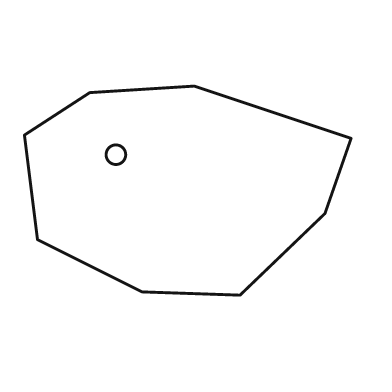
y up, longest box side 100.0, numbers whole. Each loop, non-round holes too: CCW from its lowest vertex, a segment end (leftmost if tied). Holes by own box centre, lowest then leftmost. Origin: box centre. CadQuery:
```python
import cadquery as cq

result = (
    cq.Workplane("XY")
    .moveTo(16.0, -32.0)
    .lineTo(42.0, -7.0)
    .lineTo(50.0, 16.0)
    .lineTo(2.0, 32.0)
    .lineTo(-30.0, 30.0)
    .lineTo(-50.0, 17.0)
    .lineTo(-46.0, -15.0)
    .lineTo(-14.0, -31.0)
    .close()
    .moveTo(-22.0, 11.0)
    .circle(3.0)
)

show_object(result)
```